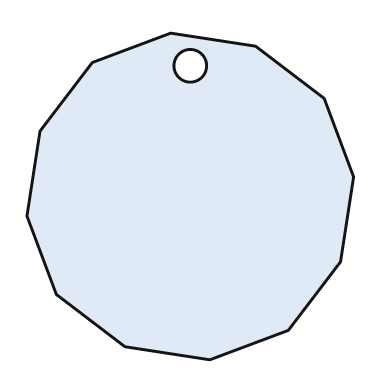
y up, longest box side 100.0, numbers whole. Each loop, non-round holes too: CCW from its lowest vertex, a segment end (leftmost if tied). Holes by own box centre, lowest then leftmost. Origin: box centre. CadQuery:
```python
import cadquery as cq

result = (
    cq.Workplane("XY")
    .moveTo(6.0, -50.0)
    .lineTo(30.0, -41.0)
    .lineTo(46.0, -20.0)
    .lineTo(50.0, 6.0)
    .lineTo(41.0, 30.0)
    .lineTo(20.0, 46.0)
    .lineTo(-6.0, 50.0)
    .lineTo(-30.0, 41.0)
    .lineTo(-46.0, 20.0)
    .lineTo(-50.0, -6.0)
    .lineTo(-41.0, -30.0)
    .lineTo(-20.0, -46.0)
    .close()
    .moveTo(0.0, 40.0)
    .circle(5.0)
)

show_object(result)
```